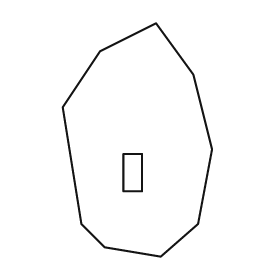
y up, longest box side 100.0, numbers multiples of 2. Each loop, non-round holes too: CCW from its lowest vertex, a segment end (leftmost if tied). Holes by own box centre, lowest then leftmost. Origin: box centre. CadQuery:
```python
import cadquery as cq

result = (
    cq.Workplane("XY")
    .moveTo(10.0, -50.0)
    .lineTo(26.0, -36.0)
    .lineTo(32.0, -4.0)
    .lineTo(24.0, 28.0)
    .lineTo(8.0, 50.0)
    .lineTo(-16.0, 38.0)
    .lineTo(-32.0, 14.0)
    .lineTo(-24.0, -36.0)
    .lineTo(-14.0, -46.0)
    .close()
    .moveTo(-6.0, -22.0)
    .lineTo(2.0, -22.0)
    .lineTo(2.0, -6.0)
    .lineTo(-6.0, -6.0)
    .close()
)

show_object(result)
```